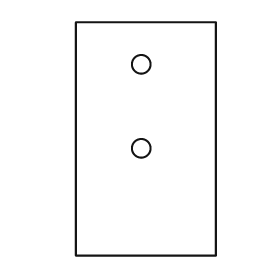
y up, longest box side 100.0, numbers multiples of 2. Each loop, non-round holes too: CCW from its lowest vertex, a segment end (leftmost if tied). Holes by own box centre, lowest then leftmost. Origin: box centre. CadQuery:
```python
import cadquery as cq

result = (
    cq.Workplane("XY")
    .moveTo(-30.0, -50.0)
    .lineTo(30.0, -50.0)
    .lineTo(30.0, 50.0)
    .lineTo(-30.0, 50.0)
    .close()
    .moveTo(-2.0, -4.0)
    .circle(4.0)
    .moveTo(-2.0, 32.0)
    .circle(4.0)
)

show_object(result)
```